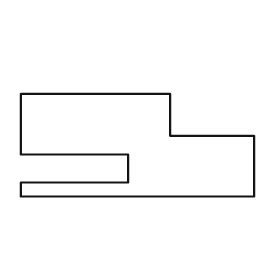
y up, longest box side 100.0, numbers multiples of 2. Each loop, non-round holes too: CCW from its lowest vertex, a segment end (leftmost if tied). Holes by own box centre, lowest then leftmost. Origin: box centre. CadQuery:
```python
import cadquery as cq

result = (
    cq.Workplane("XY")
    .moveTo(-50.0, -22.0)
    .lineTo(50.0, -22.0)
    .lineTo(50.0, 4.0)
    .lineTo(14.0, 4.0)
    .lineTo(14.0, 22.0)
    .lineTo(-50.0, 22.0)
    .lineTo(-50.0, -4.0)
    .lineTo(-4.0, -4.0)
    .lineTo(-4.0, -16.0)
    .lineTo(-50.0, -16.0)
    .close()
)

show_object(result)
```